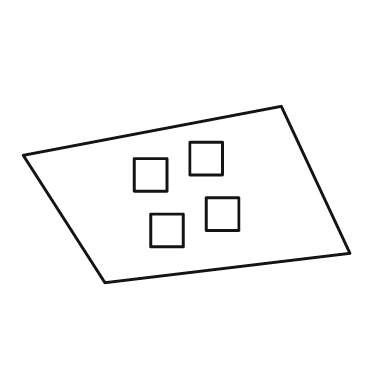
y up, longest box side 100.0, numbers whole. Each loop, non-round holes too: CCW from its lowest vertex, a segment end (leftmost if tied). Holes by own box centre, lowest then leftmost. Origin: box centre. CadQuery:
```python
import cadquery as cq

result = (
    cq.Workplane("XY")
    .moveTo(-25.0, -27.0)
    .lineTo(50.0, -18.0)
    .lineTo(29.0, 27.0)
    .lineTo(-50.0, 12.0)
    .close()
    .moveTo(-11.0, -16.0)
    .lineTo(-1.0, -16.0)
    .lineTo(-1.0, -6.0)
    .lineTo(-11.0, -6.0)
    .close()
    .moveTo(6.0, -11.0)
    .lineTo(16.0, -11.0)
    .lineTo(16.0, -1.0)
    .lineTo(6.0, -1.0)
    .close()
    .moveTo(-16.0, 1.0)
    .lineTo(-6.0, 1.0)
    .lineTo(-6.0, 11.0)
    .lineTo(-16.0, 11.0)
    .close()
    .moveTo(1.0, 6.0)
    .lineTo(11.0, 6.0)
    .lineTo(11.0, 16.0)
    .lineTo(1.0, 16.0)
    .close()
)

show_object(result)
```